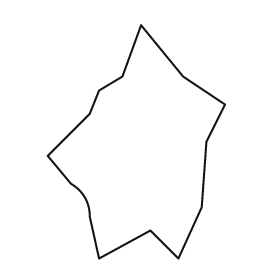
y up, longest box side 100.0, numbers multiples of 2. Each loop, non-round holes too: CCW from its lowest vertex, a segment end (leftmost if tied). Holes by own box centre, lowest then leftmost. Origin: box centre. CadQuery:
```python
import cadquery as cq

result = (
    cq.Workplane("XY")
    .moveTo(-16.0, -50.0)
    .lineTo(6.0, -38.0)
    .lineTo(18.0, -50.0)
    .lineTo(28.0, -28.0)
    .lineTo(30.0, 0.0)
    .lineTo(38.0, 16.0)
    .lineTo(20.0, 28.0)
    .lineTo(2.0, 50.0)
    .lineTo(-6.0, 28.0)
    .lineTo(-16.0, 22.0)
    .lineTo(-20.0, 12.0)
    .lineTo(-38.0, -6.0)
    .lineTo(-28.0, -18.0)
    .threePointArc((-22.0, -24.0), (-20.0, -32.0))
    .close()
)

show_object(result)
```